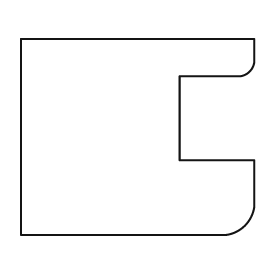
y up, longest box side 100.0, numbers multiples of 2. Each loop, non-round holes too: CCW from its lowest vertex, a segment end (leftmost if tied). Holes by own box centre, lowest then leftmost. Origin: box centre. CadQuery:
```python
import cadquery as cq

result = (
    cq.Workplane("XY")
    .moveTo(-50.0, -42.0)
    .lineTo(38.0, -42.0)
    .threePointArc((46.0, -38.0), (50.0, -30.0))
    .lineTo(50.0, -10.0)
    .lineTo(18.0, -10.0)
    .lineTo(18.0, 26.0)
    .lineTo(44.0, 26.0)
    .threePointArc((48.0, 28.0), (50.0, 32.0))
    .lineTo(50.0, 42.0)
    .lineTo(-50.0, 42.0)
    .close()
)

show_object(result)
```